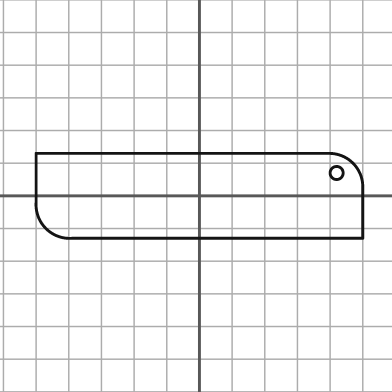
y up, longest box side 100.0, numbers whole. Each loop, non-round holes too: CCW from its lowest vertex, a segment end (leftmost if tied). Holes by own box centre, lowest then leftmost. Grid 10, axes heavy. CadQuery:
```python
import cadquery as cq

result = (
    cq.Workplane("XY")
    .moveTo(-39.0, -13.0)
    .lineTo(50.0, -13.0)
    .lineTo(50.0, 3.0)
    .threePointArc((47.0, 10.0), (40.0, 13.0))
    .lineTo(-50.0, 13.0)
    .lineTo(-50.0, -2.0)
    .threePointArc((-47.0, -10.0), (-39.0, -13.0))
    .close()
    .moveTo(42.0, 7.0)
    .circle(2.0)
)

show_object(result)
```